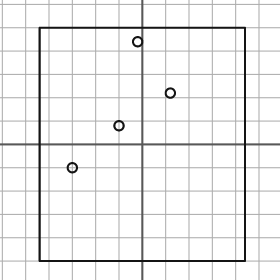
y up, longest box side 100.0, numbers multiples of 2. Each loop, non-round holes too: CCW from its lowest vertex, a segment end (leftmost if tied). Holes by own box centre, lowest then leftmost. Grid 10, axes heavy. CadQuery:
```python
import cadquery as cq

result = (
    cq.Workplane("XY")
    .moveTo(-44.0, -50.0)
    .lineTo(44.0, -50.0)
    .lineTo(44.0, 50.0)
    .lineTo(-44.0, 50.0)
    .close()
    .moveTo(-30.0, -10.0)
    .circle(2.0)
    .moveTo(-10.0, 8.0)
    .circle(2.0)
    .moveTo(12.0, 22.0)
    .circle(2.0)
    .moveTo(-2.0, 44.0)
    .circle(2.0)
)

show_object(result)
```